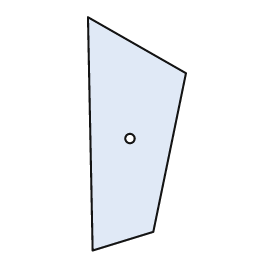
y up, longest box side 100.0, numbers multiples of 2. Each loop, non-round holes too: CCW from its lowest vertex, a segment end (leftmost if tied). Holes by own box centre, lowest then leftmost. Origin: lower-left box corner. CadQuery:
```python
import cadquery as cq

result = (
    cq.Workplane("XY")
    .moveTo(2.0, 0.0)
    .lineTo(28.0, 8.0)
    .lineTo(42.0, 76.0)
    .lineTo(0.0, 100.0)
    .close()
    .moveTo(18.0, 48.0)
    .circle(2.0)
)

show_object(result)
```